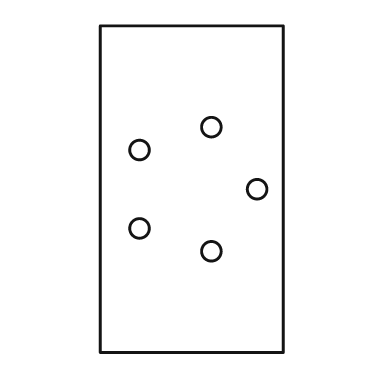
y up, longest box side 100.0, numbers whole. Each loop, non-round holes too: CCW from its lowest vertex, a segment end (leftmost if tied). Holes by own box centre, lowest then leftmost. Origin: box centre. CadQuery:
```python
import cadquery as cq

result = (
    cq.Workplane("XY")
    .moveTo(-28.0, -50.0)
    .lineTo(28.0, -50.0)
    .lineTo(28.0, 50.0)
    .lineTo(-28.0, 50.0)
    .close()
    .moveTo(6.0, -19.0)
    .circle(3.0)
    .moveTo(-16.0, -12.0)
    .circle(3.0)
    .moveTo(20.0, 0.0)
    .circle(3.0)
    .moveTo(-16.0, 12.0)
    .circle(3.0)
    .moveTo(6.0, 19.0)
    .circle(3.0)
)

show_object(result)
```